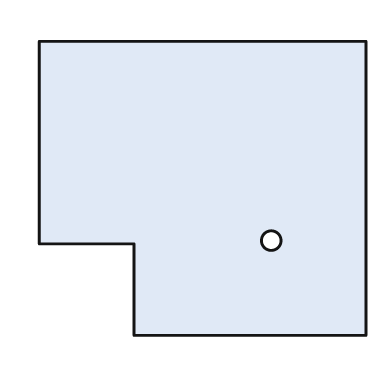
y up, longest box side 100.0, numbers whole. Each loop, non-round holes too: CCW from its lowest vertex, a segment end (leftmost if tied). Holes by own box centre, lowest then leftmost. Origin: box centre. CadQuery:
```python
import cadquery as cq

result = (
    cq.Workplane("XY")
    .moveTo(-21.0, -45.0)
    .lineTo(50.0, -45.0)
    .lineTo(50.0, 45.0)
    .lineTo(-50.0, 45.0)
    .lineTo(-50.0, -17.0)
    .lineTo(-21.0, -17.0)
    .close()
    .moveTo(21.0, -16.0)
    .circle(3.0)
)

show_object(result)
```